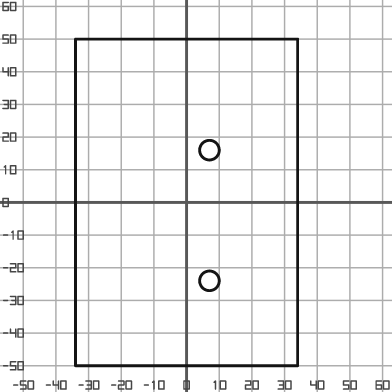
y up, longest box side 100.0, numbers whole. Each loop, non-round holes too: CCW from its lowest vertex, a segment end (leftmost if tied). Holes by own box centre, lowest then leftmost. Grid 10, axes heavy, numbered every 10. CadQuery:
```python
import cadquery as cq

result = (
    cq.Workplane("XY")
    .moveTo(-34.0, -50.0)
    .lineTo(34.0, -50.0)
    .lineTo(34.0, 50.0)
    .lineTo(-34.0, 50.0)
    .close()
    .moveTo(7.0, -24.0)
    .circle(3.0)
    .moveTo(7.0, 16.0)
    .circle(3.0)
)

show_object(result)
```